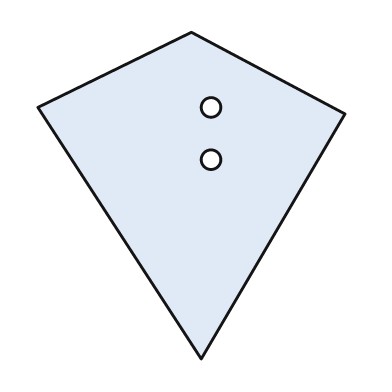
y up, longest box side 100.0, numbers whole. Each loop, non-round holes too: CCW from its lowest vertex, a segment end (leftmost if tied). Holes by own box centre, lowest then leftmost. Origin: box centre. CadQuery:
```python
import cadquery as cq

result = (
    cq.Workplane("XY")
    .moveTo(3.0, -50.0)
    .lineTo(47.0, 25.0)
    .lineTo(0.0, 50.0)
    .lineTo(-47.0, 27.0)
    .close()
    .moveTo(6.0, 11.0)
    .circle(3.0)
    .moveTo(6.0, 27.0)
    .circle(3.0)
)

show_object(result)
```